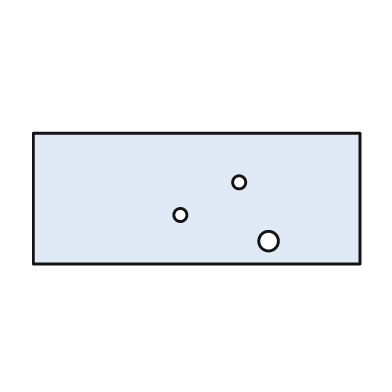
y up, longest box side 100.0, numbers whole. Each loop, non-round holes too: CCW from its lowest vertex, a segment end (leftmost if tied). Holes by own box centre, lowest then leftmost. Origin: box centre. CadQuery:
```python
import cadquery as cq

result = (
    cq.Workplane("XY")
    .moveTo(-50.0, -20.0)
    .lineTo(50.0, -20.0)
    .lineTo(50.0, 20.0)
    .lineTo(-50.0, 20.0)
    .close()
    .moveTo(22.0, -13.0)
    .circle(3.0)
    .moveTo(-5.0, -5.0)
    .circle(2.0)
    .moveTo(13.0, 5.0)
    .circle(2.0)
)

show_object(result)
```